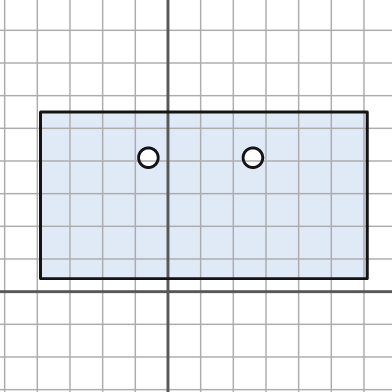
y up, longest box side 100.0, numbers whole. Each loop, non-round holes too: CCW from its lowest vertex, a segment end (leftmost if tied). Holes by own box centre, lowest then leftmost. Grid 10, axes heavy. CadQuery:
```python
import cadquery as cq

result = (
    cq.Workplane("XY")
    .moveTo(-39.0, 4.0)
    .lineTo(61.0, 4.0)
    .lineTo(61.0, 55.0)
    .lineTo(-39.0, 55.0)
    .close()
    .moveTo(-6.0, 41.0)
    .circle(3.0)
    .moveTo(26.0, 41.0)
    .circle(3.0)
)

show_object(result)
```